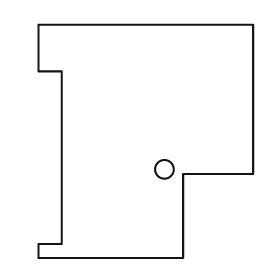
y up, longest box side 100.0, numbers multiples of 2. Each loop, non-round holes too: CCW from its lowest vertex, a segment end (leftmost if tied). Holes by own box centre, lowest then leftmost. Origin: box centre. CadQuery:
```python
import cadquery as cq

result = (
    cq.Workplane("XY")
    .moveTo(-46.0, -50.0)
    .lineTo(16.0, -50.0)
    .lineTo(16.0, -14.0)
    .lineTo(46.0, -14.0)
    .lineTo(46.0, 50.0)
    .lineTo(-46.0, 50.0)
    .lineTo(-46.0, 30.0)
    .lineTo(-36.0, 30.0)
    .lineTo(-36.0, -44.0)
    .lineTo(-46.0, -44.0)
    .close()
    .moveTo(8.0, -12.0)
    .circle(4.0)
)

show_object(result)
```